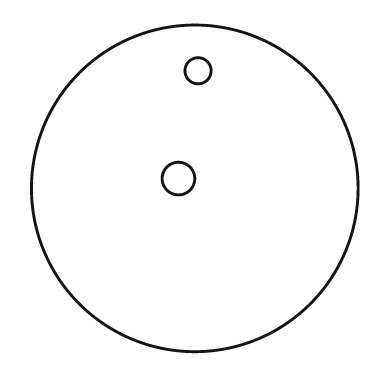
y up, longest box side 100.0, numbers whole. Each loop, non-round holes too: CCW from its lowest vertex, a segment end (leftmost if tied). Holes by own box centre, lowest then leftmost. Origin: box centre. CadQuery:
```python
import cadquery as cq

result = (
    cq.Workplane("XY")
    .moveTo(0.0, 0.0)
    .circle(50.0)
    .moveTo(-5.0, 3.0)
    .circle(5.0)
    .moveTo(1.0, 36.0)
    .circle(4.0)
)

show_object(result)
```